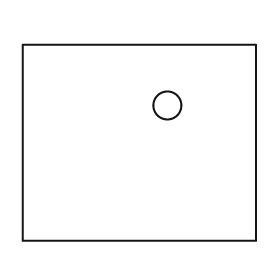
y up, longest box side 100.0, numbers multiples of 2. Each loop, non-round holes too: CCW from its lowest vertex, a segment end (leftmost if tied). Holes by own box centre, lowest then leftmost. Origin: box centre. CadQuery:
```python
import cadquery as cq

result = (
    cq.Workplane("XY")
    .moveTo(-50.0, -42.0)
    .lineTo(50.0, -42.0)
    .lineTo(50.0, 42.0)
    .lineTo(-50.0, 42.0)
    .close()
    .moveTo(12.0, 16.0)
    .circle(6.0)
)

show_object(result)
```